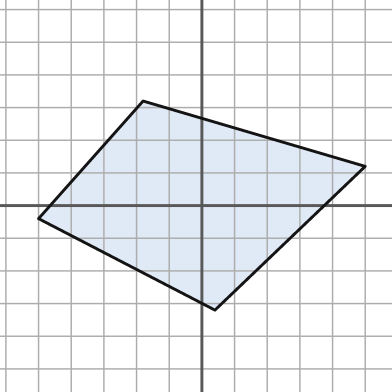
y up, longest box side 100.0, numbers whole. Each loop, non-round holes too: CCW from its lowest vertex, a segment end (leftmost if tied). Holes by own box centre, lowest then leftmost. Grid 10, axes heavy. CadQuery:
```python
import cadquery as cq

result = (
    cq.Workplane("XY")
    .moveTo(4.0, -32.0)
    .lineTo(50.0, 12.0)
    .lineTo(-18.0, 32.0)
    .lineTo(-50.0, -4.0)
    .close()
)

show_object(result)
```